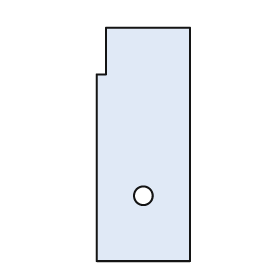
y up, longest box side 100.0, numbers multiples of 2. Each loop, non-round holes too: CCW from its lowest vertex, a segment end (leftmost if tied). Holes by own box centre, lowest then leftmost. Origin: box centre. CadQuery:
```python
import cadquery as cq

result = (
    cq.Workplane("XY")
    .moveTo(-20.0, -50.0)
    .lineTo(20.0, -50.0)
    .lineTo(20.0, 50.0)
    .lineTo(-16.0, 50.0)
    .lineTo(-16.0, 30.0)
    .lineTo(-20.0, 30.0)
    .close()
    .moveTo(0.0, -22.0)
    .circle(4.0)
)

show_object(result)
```